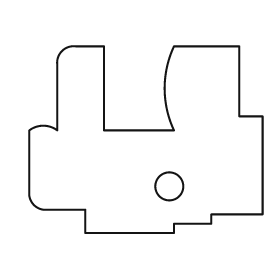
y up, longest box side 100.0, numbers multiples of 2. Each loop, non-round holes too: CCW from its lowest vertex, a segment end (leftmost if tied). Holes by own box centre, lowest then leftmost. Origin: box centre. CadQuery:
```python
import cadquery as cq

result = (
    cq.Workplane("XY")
    .moveTo(-26.0, -40.0)
    .lineTo(12.0, -40.0)
    .lineTo(12.0, -36.0)
    .lineTo(28.0, -36.0)
    .lineTo(28.0, -32.0)
    .lineTo(50.0, -32.0)
    .lineTo(50.0, 10.0)
    .lineTo(40.0, 10.0)
    .lineTo(40.0, 40.0)
    .lineTo(12.0, 40.0)
    .threePointArc((8.0, 22.0), (12.0, 4.0))
    .lineTo(-18.0, 4.0)
    .lineTo(-18.0, 40.0)
    .lineTo(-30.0, 40.0)
    .threePointArc((-36.0, 38.0), (-38.0, 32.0))
    .lineTo(-38.0, 4.0)
    .threePointArc((-44.0, 6.0), (-50.0, 4.0))
    .lineTo(-50.0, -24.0)
    .threePointArc((-48.0, -28.0), (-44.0, -30.0))
    .lineTo(-26.0, -30.0)
    .close()
    .moveTo(10.0, -20.0)
    .circle(6.0)
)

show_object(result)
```